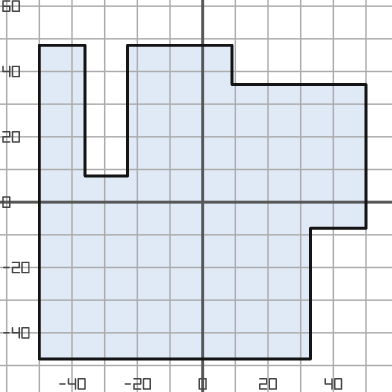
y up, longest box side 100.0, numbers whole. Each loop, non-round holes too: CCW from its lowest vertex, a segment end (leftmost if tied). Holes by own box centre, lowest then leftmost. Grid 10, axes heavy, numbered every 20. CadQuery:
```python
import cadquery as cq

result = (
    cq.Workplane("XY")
    .moveTo(-50.0, -48.0)
    .lineTo(33.0, -48.0)
    .lineTo(33.0, -8.0)
    .lineTo(50.0, -8.0)
    .lineTo(50.0, 36.0)
    .lineTo(9.0, 36.0)
    .lineTo(9.0, 48.0)
    .lineTo(-23.0, 48.0)
    .lineTo(-23.0, 8.0)
    .lineTo(-36.0, 8.0)
    .lineTo(-36.0, 48.0)
    .lineTo(-50.0, 48.0)
    .close()
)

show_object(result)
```